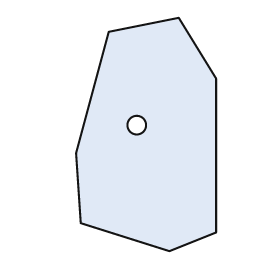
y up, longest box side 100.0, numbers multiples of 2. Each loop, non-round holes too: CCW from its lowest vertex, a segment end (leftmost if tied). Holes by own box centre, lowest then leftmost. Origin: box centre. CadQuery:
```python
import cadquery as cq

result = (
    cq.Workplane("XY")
    .moveTo(10.0, -50.0)
    .lineTo(30.0, -42.0)
    .lineTo(30.0, 24.0)
    .lineTo(14.0, 50.0)
    .lineTo(-16.0, 44.0)
    .lineTo(-30.0, -8.0)
    .lineTo(-28.0, -38.0)
    .close()
    .moveTo(-4.0, 4.0)
    .circle(4.0)
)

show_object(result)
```